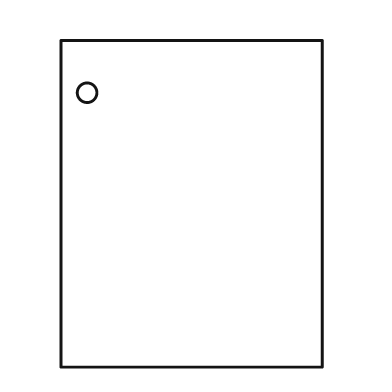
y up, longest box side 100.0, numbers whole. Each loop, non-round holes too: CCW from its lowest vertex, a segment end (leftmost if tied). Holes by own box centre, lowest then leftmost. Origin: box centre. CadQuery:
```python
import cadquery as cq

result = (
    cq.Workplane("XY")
    .moveTo(-40.0, -50.0)
    .lineTo(40.0, -50.0)
    .lineTo(40.0, 50.0)
    .lineTo(-40.0, 50.0)
    .close()
    .moveTo(-32.0, 34.0)
    .circle(3.0)
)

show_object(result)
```